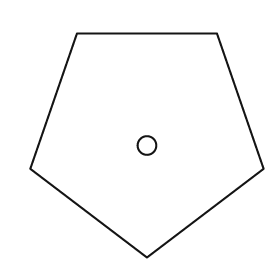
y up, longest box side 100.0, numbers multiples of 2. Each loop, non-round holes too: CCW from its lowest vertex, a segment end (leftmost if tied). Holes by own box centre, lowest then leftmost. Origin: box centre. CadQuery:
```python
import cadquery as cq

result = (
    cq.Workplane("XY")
    .moveTo(0.0, -48.0)
    .lineTo(50.0, -10.0)
    .lineTo(30.0, 48.0)
    .lineTo(-30.0, 48.0)
    .lineTo(-50.0, -10.0)
    .close()
    .moveTo(0.0, 0.0)
    .circle(4.0)
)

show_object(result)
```